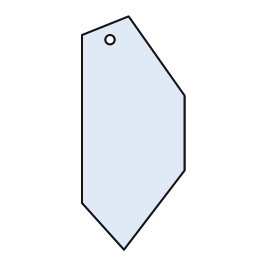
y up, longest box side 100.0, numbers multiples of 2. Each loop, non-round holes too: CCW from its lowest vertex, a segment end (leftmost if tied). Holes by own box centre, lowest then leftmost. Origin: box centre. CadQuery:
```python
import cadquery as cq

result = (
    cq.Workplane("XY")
    .moveTo(-4.0, -50.0)
    .lineTo(22.0, -16.0)
    .lineTo(22.0, 16.0)
    .lineTo(-2.0, 50.0)
    .lineTo(-22.0, 42.0)
    .lineTo(-22.0, -30.0)
    .close()
    .moveTo(-10.0, 40.0)
    .circle(2.0)
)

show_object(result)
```